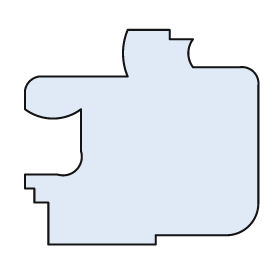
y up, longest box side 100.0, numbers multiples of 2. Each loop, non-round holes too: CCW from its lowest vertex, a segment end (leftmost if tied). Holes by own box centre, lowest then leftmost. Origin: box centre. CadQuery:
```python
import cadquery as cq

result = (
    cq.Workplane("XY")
    .moveTo(-40.0, -46.0)
    .lineTo(6.0, -46.0)
    .lineTo(6.0, -42.0)
    .lineTo(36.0, -42.0)
    .threePointArc((46.0, -38.0), (50.0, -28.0))
    .lineTo(50.0, 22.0)
    .threePointArc((48.0, 28.0), (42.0, 30.0))
    .lineTo(22.0, 30.0)
    .threePointArc((20.0, 36.0), (22.0, 42.0))
    .lineTo(12.0, 42.0)
    .lineTo(12.0, 46.0)
    .lineTo(-6.0, 46.0)
    .threePointArc((-8.0, 36.0), (-6.0, 26.0))
    .lineTo(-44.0, 26.0)
    .threePointArc((-48.0, 24.0), (-50.0, 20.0))
    .lineTo(-50.0, 12.0)
    .threePointArc((-38.0, 8.0), (-26.0, 12.0))
    .lineTo(-26.0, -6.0)
    .threePointArc((-28.0, -14.0), (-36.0, -16.0))
    .lineTo(-50.0, -16.0)
    .lineTo(-50.0, -22.0)
    .lineTo(-46.0, -22.0)
    .lineTo(-46.0, -28.0)
    .lineTo(-40.0, -28.0)
    .close()
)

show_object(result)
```